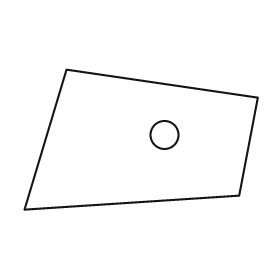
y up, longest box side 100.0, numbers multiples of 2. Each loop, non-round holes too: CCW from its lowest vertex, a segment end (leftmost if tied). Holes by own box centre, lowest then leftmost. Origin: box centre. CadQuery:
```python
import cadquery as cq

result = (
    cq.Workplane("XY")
    .moveTo(-50.0, -30.0)
    .lineTo(42.0, -24.0)
    .lineTo(50.0, 18.0)
    .lineTo(-32.0, 30.0)
    .close()
    .moveTo(10.0, 2.0)
    .circle(6.0)
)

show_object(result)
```